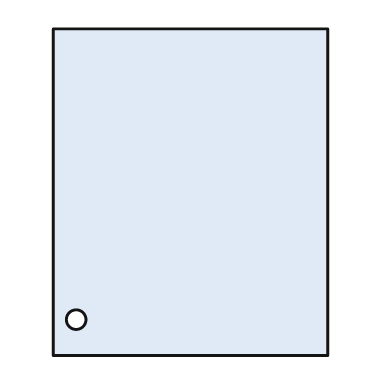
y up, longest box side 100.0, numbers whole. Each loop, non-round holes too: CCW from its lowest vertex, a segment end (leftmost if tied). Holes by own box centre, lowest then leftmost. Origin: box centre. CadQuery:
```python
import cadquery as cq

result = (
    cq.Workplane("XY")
    .moveTo(-42.0, -50.0)
    .lineTo(42.0, -50.0)
    .lineTo(42.0, 50.0)
    .lineTo(-42.0, 50.0)
    .close()
    .moveTo(-35.0, -39.0)
    .circle(3.0)
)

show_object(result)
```